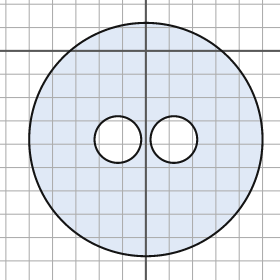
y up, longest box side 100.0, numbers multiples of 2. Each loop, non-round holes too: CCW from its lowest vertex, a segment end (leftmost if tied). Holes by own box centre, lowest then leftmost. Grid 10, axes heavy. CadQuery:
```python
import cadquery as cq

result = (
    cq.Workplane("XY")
    .moveTo(0.0, -38.0)
    .circle(50.0)
    .moveTo(-12.0, -38.0)
    .circle(10.0)
    .moveTo(12.0, -38.0)
    .circle(10.0)
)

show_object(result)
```